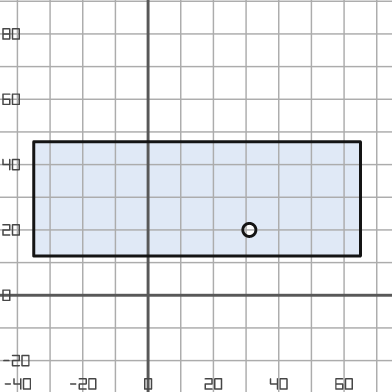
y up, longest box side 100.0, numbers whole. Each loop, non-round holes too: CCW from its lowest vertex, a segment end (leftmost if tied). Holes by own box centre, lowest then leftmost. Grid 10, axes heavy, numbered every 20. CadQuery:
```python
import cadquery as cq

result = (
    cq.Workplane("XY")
    .moveTo(-35.0, 12.0)
    .lineTo(65.0, 12.0)
    .lineTo(65.0, 47.0)
    .lineTo(-35.0, 47.0)
    .close()
    .moveTo(31.0, 20.0)
    .circle(2.0)
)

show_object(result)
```